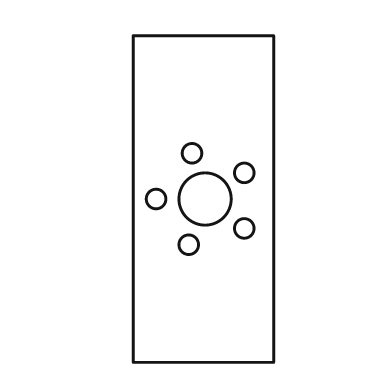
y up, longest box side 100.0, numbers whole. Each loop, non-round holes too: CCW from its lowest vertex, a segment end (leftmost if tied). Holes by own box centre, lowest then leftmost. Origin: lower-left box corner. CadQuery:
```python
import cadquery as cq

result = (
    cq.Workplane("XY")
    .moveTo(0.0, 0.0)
    .lineTo(43.0, 0.0)
    .lineTo(43.0, 100.0)
    .lineTo(0.0, 100.0)
    .close()
    .moveTo(17.0, 36.0)
    .circle(3.0)
    .moveTo(34.0, 41.0)
    .circle(3.0)
    .moveTo(7.0, 50.0)
    .circle(3.0)
    .moveTo(22.0, 50.0)
    .circle(8.0)
    .moveTo(34.0, 58.0)
    .circle(3.0)
    .moveTo(18.0, 64.0)
    .circle(3.0)
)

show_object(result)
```